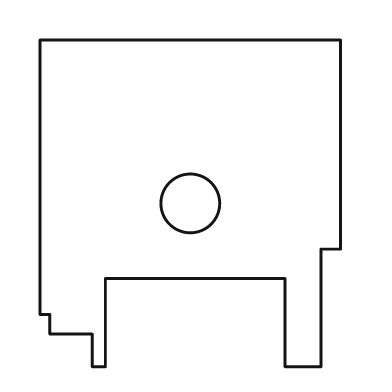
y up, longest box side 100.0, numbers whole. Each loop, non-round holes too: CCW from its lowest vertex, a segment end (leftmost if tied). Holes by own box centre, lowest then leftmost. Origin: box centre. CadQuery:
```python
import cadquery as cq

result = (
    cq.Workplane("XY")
    .moveTo(-30.0, -50.0)
    .lineTo(-26.0, -50.0)
    .lineTo(-26.0, -23.0)
    .lineTo(29.0, -23.0)
    .lineTo(29.0, -50.0)
    .lineTo(40.0, -50.0)
    .lineTo(40.0, -14.0)
    .lineTo(46.0, -14.0)
    .lineTo(46.0, 50.0)
    .lineTo(-46.0, 50.0)
    .lineTo(-46.0, -34.0)
    .lineTo(-43.0, -34.0)
    .lineTo(-43.0, -40.0)
    .lineTo(-30.0, -40.0)
    .close()
    .moveTo(0.0, 0.0)
    .circle(9.0)
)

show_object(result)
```